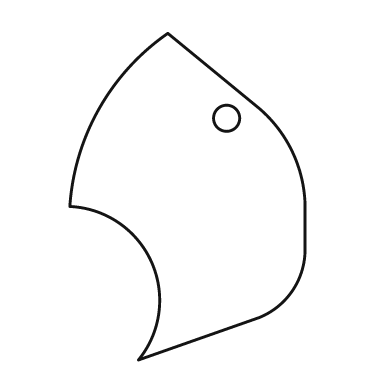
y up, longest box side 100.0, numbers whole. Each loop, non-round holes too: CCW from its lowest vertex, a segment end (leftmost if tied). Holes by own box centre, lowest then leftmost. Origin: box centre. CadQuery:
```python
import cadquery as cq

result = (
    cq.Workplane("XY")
    .moveTo(-15.0, -50.0)
    .lineTo(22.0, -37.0)
    .threePointArc((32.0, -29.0), (36.0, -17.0))
    .lineTo(36.0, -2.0)
    .threePointArc((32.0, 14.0), (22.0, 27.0))
    .lineTo(-6.0, 50.0)
    .threePointArc((-27.0, 27.0), (-36.0, -3.0))
    .threePointArc((-11.0, -20.0), (-15.0, -50.0))
    .close()
    .moveTo(12.0, 24.0)
    .circle(4.0)
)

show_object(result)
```